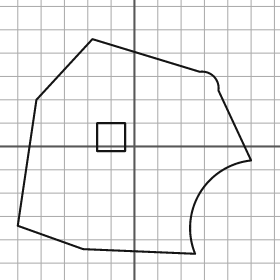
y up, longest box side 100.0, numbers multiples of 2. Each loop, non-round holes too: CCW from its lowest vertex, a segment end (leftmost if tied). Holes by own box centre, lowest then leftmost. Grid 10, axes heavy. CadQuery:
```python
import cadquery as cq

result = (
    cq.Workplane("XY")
    .moveTo(26.0, -46.0)
    .threePointArc((28.0, -20.0), (50.0, -6.0))
    .lineTo(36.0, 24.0)
    .threePointArc((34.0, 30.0), (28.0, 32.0))
    .lineTo(-18.0, 46.0)
    .lineTo(-42.0, 20.0)
    .lineTo(-50.0, -34.0)
    .lineTo(-22.0, -44.0)
    .close()
    .moveTo(-16.0, -2.0)
    .lineTo(-4.0, -2.0)
    .lineTo(-4.0, 10.0)
    .lineTo(-16.0, 10.0)
    .close()
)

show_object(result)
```